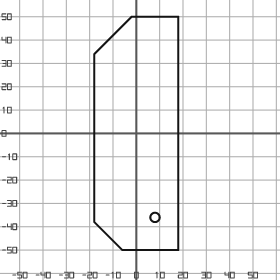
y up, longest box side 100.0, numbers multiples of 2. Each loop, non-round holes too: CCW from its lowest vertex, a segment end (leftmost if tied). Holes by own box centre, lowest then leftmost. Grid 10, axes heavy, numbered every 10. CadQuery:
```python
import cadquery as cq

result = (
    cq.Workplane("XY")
    .moveTo(-6.0, -50.0)
    .lineTo(18.0, -50.0)
    .lineTo(18.0, 50.0)
    .lineTo(-2.0, 50.0)
    .lineTo(-18.0, 34.0)
    .lineTo(-18.0, -38.0)
    .close()
    .moveTo(8.0, -36.0)
    .circle(2.0)
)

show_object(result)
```